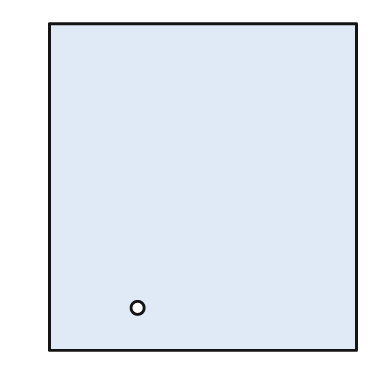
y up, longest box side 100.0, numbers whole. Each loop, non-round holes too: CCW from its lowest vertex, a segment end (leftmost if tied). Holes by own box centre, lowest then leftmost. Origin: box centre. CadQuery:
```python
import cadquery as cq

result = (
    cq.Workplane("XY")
    .moveTo(-47.0, -50.0)
    .lineTo(47.0, -50.0)
    .lineTo(47.0, 50.0)
    .lineTo(-47.0, 50.0)
    .close()
    .moveTo(-20.0, -37.0)
    .circle(2.0)
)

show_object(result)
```